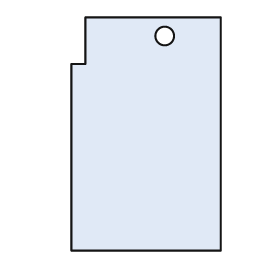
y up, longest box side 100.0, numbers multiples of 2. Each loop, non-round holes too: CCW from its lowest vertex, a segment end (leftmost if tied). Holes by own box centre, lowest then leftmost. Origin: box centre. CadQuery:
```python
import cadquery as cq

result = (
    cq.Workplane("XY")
    .moveTo(-32.0, -50.0)
    .lineTo(32.0, -50.0)
    .lineTo(32.0, 50.0)
    .lineTo(-26.0, 50.0)
    .lineTo(-26.0, 30.0)
    .lineTo(-32.0, 30.0)
    .close()
    .moveTo(8.0, 42.0)
    .circle(4.0)
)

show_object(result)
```